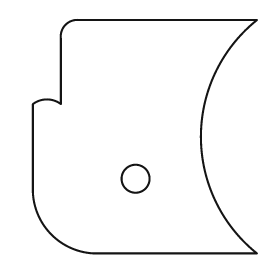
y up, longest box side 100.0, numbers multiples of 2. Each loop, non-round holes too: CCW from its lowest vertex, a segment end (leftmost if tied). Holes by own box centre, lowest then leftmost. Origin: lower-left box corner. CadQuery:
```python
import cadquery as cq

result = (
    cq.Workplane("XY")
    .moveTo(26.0, 0.0)
    .lineTo(96.0, 0.0)
    .threePointArc((72.0, 50.0), (96.0, 100.0))
    .lineTo(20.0, 100.0)
    .threePointArc((14.0, 98.0), (12.0, 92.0))
    .lineTo(12.0, 64.0)
    .threePointArc((6.0, 66.0), (0.0, 64.0))
    .lineTo(0.0, 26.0)
    .threePointArc((8.0, 8.0), (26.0, 0.0))
    .close()
    .moveTo(44.0, 32.0)
    .circle(6.0)
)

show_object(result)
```